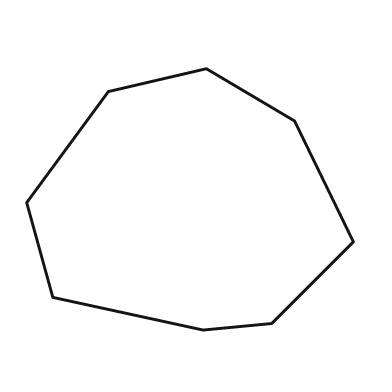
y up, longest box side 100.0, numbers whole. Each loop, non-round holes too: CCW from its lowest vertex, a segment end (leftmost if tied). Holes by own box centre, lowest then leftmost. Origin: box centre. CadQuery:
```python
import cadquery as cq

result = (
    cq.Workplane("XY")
    .moveTo(4.0, -40.0)
    .lineTo(25.0, -38.0)
    .lineTo(50.0, -13.0)
    .lineTo(32.0, 24.0)
    .lineTo(5.0, 40.0)
    .lineTo(-25.0, 33.0)
    .lineTo(-50.0, -1.0)
    .lineTo(-42.0, -30.0)
    .close()
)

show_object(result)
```